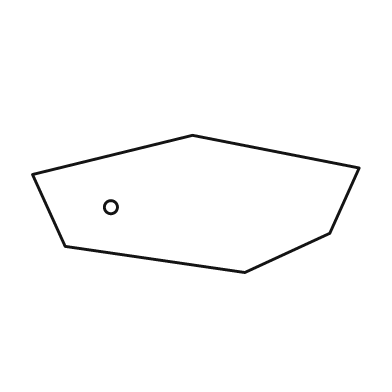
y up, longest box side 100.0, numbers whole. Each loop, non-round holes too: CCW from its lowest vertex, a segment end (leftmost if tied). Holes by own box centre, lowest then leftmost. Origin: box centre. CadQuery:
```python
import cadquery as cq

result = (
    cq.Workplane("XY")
    .moveTo(15.0, -21.0)
    .lineTo(41.0, -9.0)
    .lineTo(50.0, 11.0)
    .lineTo(-1.0, 21.0)
    .lineTo(-50.0, 9.0)
    .lineTo(-40.0, -13.0)
    .close()
    .moveTo(-26.0, -1.0)
    .circle(2.0)
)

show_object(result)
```